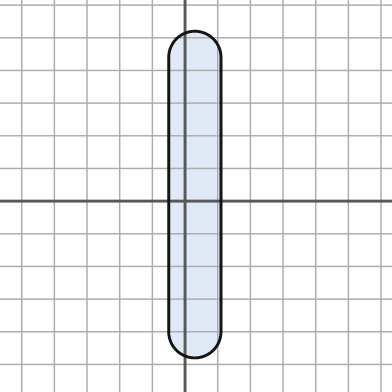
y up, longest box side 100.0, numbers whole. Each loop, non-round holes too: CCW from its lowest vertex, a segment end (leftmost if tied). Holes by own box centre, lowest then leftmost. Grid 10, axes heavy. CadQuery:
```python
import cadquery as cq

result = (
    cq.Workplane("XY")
    .moveTo(-5.0, -40.0)
    .threePointArc((3.0, -48.0), (11.0, -40.0))
    .lineTo(11.0, 44.0)
    .threePointArc((3.0, 52.0), (-5.0, 44.0))
    .close()
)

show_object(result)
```